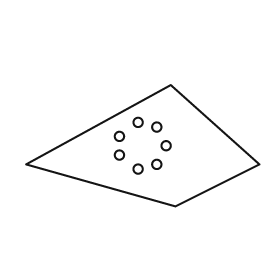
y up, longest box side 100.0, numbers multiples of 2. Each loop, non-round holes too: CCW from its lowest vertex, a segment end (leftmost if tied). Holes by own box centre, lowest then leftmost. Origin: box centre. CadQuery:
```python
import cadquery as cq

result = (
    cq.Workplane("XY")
    .moveTo(14.0, -26.0)
    .lineTo(50.0, -8.0)
    .lineTo(12.0, 26.0)
    .lineTo(-50.0, -8.0)
    .close()
    .moveTo(-2.0, -10.0)
    .circle(2.0)
    .moveTo(6.0, -8.0)
    .circle(2.0)
    .moveTo(-10.0, -4.0)
    .circle(2.0)
    .moveTo(10.0, 0.0)
    .circle(2.0)
    .moveTo(-10.0, 4.0)
    .circle(2.0)
    .moveTo(6.0, 8.0)
    .circle(2.0)
    .moveTo(-2.0, 10.0)
    .circle(2.0)
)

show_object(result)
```